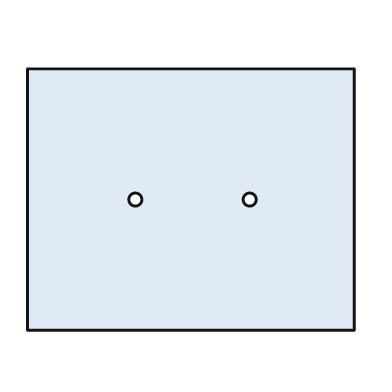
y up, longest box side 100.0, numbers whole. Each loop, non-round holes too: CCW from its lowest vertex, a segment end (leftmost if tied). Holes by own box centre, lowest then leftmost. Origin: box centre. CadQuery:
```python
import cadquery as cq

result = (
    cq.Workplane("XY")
    .moveTo(-50.0, -40.0)
    .lineTo(50.0, -40.0)
    .lineTo(50.0, 40.0)
    .lineTo(-50.0, 40.0)
    .close()
    .moveTo(-17.0, 0.0)
    .circle(2.0)
    .moveTo(18.0, 0.0)
    .circle(2.0)
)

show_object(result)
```